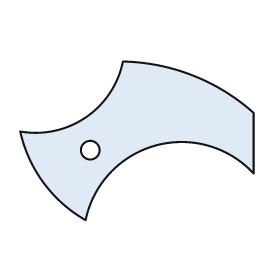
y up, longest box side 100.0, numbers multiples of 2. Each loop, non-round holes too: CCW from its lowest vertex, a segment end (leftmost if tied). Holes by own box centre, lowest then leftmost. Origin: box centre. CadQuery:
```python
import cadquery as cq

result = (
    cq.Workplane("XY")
    .moveTo(-22.0, -34.0)
    .threePointArc((8.0, -2.0), (50.0, -14.0))
    .lineTo(50.0, 12.0)
    .threePointArc((24.0, 28.0), (-6.0, 34.0))
    .threePointArc((-22.0, 10.0), (-50.0, 4.0))
    .threePointArc((-40.0, -18.0), (-22.0, -34.0))
    .close()
    .moveTo(-20.0, -4.0)
    .circle(4.0)
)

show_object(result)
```